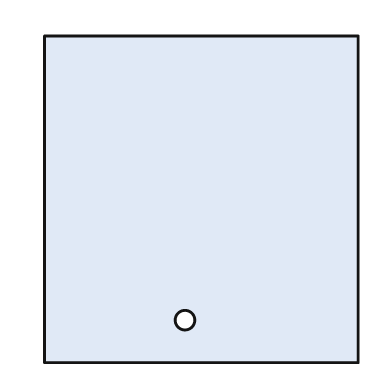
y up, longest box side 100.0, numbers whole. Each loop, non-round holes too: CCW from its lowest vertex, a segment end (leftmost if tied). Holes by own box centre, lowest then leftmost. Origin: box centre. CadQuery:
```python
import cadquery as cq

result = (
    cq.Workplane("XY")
    .moveTo(-48.0, -50.0)
    .lineTo(48.0, -50.0)
    .lineTo(48.0, 50.0)
    .lineTo(-48.0, 50.0)
    .close()
    .moveTo(-5.0, -37.0)
    .circle(3.0)
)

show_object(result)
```